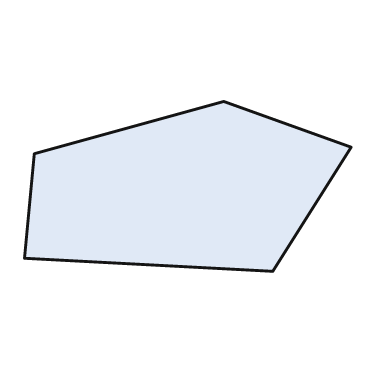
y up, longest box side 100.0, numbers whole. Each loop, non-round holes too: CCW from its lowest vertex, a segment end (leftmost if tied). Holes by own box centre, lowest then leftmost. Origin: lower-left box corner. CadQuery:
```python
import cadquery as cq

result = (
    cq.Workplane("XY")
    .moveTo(76.0, 0.0)
    .lineTo(100.0, 38.0)
    .lineTo(61.0, 52.0)
    .lineTo(3.0, 36.0)
    .lineTo(0.0, 4.0)
    .close()
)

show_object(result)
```